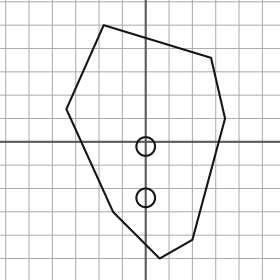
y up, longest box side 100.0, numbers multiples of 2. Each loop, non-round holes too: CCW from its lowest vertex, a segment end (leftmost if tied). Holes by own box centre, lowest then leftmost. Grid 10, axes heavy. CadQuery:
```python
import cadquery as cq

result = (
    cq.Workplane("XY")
    .moveTo(6.0, -50.0)
    .lineTo(20.0, -42.0)
    .lineTo(34.0, 10.0)
    .lineTo(28.0, 36.0)
    .lineTo(-18.0, 50.0)
    .lineTo(-34.0, 14.0)
    .lineTo(-14.0, -30.0)
    .close()
    .moveTo(0.0, -24.0)
    .circle(4.0)
    .moveTo(0.0, -2.0)
    .circle(4.0)
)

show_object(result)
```